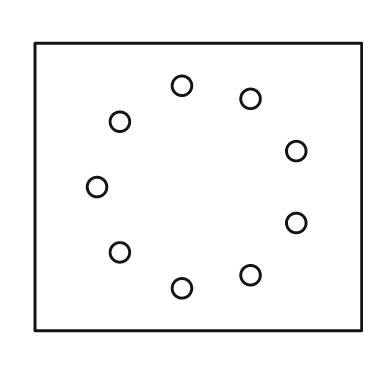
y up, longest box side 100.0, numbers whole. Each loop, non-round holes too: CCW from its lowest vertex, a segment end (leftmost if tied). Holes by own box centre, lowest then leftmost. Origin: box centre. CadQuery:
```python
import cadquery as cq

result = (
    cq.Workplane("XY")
    .moveTo(-50.0, -44.0)
    .lineTo(50.0, -44.0)
    .lineTo(50.0, 44.0)
    .lineTo(-50.0, 44.0)
    .close()
    .moveTo(-5.0, -31.0)
    .circle(3.0)
    .moveTo(16.0, -27.0)
    .circle(3.0)
    .moveTo(-24.0, -20.0)
    .circle(3.0)
    .moveTo(30.0, -11.0)
    .circle(3.0)
    .moveTo(-31.0, 0.0)
    .circle(3.0)
    .moveTo(30.0, 11.0)
    .circle(3.0)
    .moveTo(-24.0, 20.0)
    .circle(3.0)
    .moveTo(16.0, 27.0)
    .circle(3.0)
    .moveTo(-5.0, 31.0)
    .circle(3.0)
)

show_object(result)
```